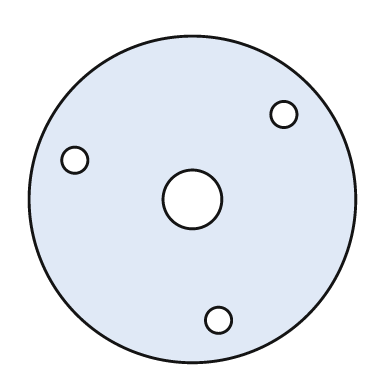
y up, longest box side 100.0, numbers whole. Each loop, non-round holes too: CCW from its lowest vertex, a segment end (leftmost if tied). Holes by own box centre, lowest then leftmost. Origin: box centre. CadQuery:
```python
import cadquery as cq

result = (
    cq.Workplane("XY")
    .moveTo(0.0, 0.0)
    .circle(50.0)
    .moveTo(8.0, -37.0)
    .circle(4.0)
    .moveTo(0.0, 0.0)
    .circle(9.0)
    .moveTo(-36.0, 12.0)
    .circle(4.0)
    .moveTo(28.0, 26.0)
    .circle(4.0)
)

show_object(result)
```